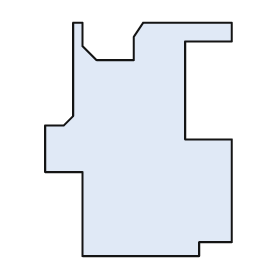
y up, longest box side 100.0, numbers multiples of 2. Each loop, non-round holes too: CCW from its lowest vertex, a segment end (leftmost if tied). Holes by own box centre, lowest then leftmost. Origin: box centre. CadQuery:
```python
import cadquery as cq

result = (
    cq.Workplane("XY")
    .moveTo(-24.0, -50.0)
    .lineTo(26.0, -50.0)
    .lineTo(26.0, -44.0)
    .lineTo(40.0, -44.0)
    .lineTo(40.0, 0.0)
    .lineTo(20.0, 0.0)
    .lineTo(20.0, 42.0)
    .lineTo(40.0, 42.0)
    .lineTo(40.0, 50.0)
    .lineTo(2.0, 50.0)
    .lineTo(-2.0, 44.0)
    .lineTo(-2.0, 34.0)
    .lineTo(-18.0, 34.0)
    .lineTo(-24.0, 40.0)
    .lineTo(-24.0, 50.0)
    .lineTo(-28.0, 50.0)
    .lineTo(-28.0, 10.0)
    .lineTo(-32.0, 6.0)
    .lineTo(-40.0, 6.0)
    .lineTo(-40.0, -14.0)
    .lineTo(-24.0, -14.0)
    .close()
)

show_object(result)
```